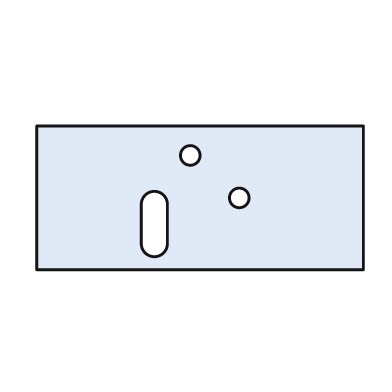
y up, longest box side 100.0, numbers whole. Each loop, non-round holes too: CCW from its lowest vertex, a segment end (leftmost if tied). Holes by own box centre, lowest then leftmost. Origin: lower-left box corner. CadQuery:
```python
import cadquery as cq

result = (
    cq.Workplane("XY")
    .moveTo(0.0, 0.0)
    .lineTo(100.0, 0.0)
    .lineTo(100.0, 44.0)
    .lineTo(0.0, 44.0)
    .close()
    .moveTo(32.0, 8.0)
    .threePointArc((36.0, 4.0), (40.0, 8.0))
    .lineTo(40.0, 20.0)
    .threePointArc((36.0, 24.0), (32.0, 20.0))
    .close()
    .moveTo(62.0, 22.0)
    .circle(3.0)
    .moveTo(47.0, 35.0)
    .circle(3.0)
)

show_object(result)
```